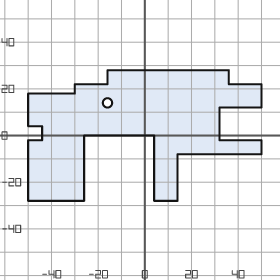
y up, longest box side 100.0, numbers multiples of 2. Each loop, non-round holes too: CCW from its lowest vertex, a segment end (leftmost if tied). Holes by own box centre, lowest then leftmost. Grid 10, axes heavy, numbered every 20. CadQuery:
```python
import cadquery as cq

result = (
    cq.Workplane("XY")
    .moveTo(-50.0, -28.0)
    .lineTo(-26.0, -28.0)
    .lineTo(-26.0, 0.0)
    .lineTo(4.0, 0.0)
    .lineTo(4.0, -28.0)
    .lineTo(14.0, -28.0)
    .lineTo(14.0, -8.0)
    .lineTo(50.0, -8.0)
    .lineTo(50.0, -2.0)
    .lineTo(32.0, -2.0)
    .lineTo(32.0, 12.0)
    .lineTo(50.0, 12.0)
    .lineTo(50.0, 22.0)
    .lineTo(36.0, 22.0)
    .lineTo(36.0, 28.0)
    .lineTo(-16.0, 28.0)
    .lineTo(-16.0, 22.0)
    .lineTo(-30.0, 22.0)
    .lineTo(-30.0, 18.0)
    .lineTo(-50.0, 18.0)
    .lineTo(-50.0, 4.0)
    .lineTo(-44.0, 4.0)
    .lineTo(-44.0, -2.0)
    .lineTo(-50.0, -2.0)
    .close()
    .moveTo(-16.0, 14.0)
    .circle(2.0)
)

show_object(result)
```